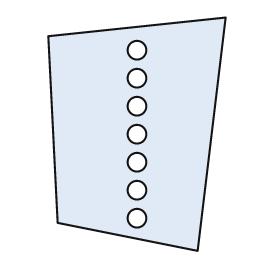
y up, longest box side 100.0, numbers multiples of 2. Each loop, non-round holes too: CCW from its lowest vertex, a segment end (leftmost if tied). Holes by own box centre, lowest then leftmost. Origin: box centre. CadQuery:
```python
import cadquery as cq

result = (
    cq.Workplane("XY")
    .moveTo(26.0, -50.0)
    .lineTo(38.0, 50.0)
    .lineTo(-38.0, 42.0)
    .lineTo(-34.0, -38.0)
    .close()
    .moveTo(0.0, -36.0)
    .circle(4.0)
    .moveTo(0.0, -24.0)
    .circle(4.0)
    .moveTo(0.0, -12.0)
    .circle(4.0)
    .moveTo(0.0, 0.0)
    .circle(4.0)
    .moveTo(0.0, 12.0)
    .circle(4.0)
    .moveTo(0.0, 24.0)
    .circle(4.0)
    .moveTo(0.0, 36.0)
    .circle(4.0)
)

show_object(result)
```